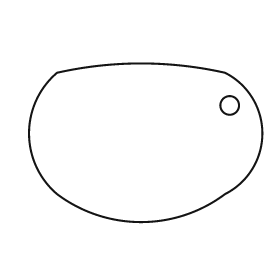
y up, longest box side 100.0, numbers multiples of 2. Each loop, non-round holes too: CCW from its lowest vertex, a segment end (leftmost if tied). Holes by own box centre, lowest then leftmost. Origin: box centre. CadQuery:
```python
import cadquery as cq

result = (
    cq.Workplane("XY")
    .moveTo(-38.0, -22.0)
    .threePointArc((-2.0, -34.0), (34.0, -22.0))
    .threePointArc((50.0, 4.0), (34.0, 30.0))
    .threePointArc((-2.0, 34.0), (-38.0, 30.0))
    .threePointArc((-50.0, 4.0), (-38.0, -22.0))
    .close()
    .moveTo(36.0, 16.0)
    .circle(4.0)
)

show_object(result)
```